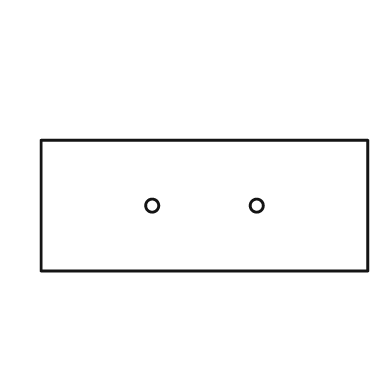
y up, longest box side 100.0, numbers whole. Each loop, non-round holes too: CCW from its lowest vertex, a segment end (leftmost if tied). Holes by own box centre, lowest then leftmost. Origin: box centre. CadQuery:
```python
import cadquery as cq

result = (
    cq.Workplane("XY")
    .moveTo(-50.0, -20.0)
    .lineTo(50.0, -20.0)
    .lineTo(50.0, 20.0)
    .lineTo(-50.0, 20.0)
    .close()
    .moveTo(-16.0, 0.0)
    .circle(2.0)
    .moveTo(16.0, 0.0)
    .circle(2.0)
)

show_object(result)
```